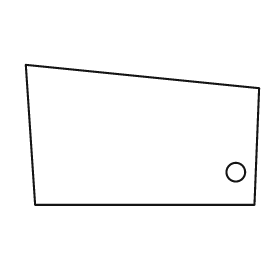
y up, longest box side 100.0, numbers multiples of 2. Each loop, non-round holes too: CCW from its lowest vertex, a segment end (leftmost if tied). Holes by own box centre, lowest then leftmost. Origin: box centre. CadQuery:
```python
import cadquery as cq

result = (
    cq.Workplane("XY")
    .moveTo(-46.0, -30.0)
    .lineTo(48.0, -30.0)
    .lineTo(50.0, 20.0)
    .lineTo(-50.0, 30.0)
    .close()
    .moveTo(40.0, -16.0)
    .circle(4.0)
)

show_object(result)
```